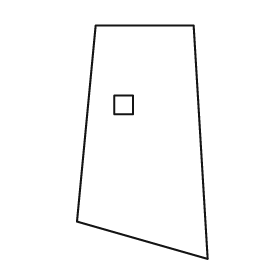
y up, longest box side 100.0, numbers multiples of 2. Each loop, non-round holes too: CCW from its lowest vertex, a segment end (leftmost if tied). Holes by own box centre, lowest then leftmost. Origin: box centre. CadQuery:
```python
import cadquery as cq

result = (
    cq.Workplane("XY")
    .moveTo(28.0, -50.0)
    .lineTo(22.0, 50.0)
    .lineTo(-20.0, 50.0)
    .lineTo(-28.0, -34.0)
    .close()
    .moveTo(-12.0, 12.0)
    .lineTo(-4.0, 12.0)
    .lineTo(-4.0, 20.0)
    .lineTo(-12.0, 20.0)
    .close()
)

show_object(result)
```